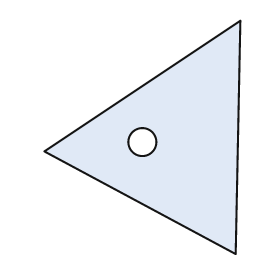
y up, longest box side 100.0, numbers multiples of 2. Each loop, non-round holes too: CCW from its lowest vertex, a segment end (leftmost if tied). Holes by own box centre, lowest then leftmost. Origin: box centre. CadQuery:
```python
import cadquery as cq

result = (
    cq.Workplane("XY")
    .moveTo(40.0, -50.0)
    .lineTo(42.0, 50.0)
    .lineTo(-42.0, -6.0)
    .close()
    .moveTo(0.0, -2.0)
    .circle(6.0)
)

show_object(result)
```